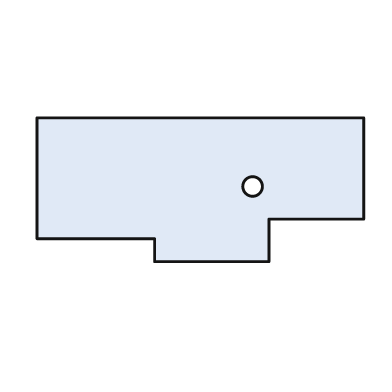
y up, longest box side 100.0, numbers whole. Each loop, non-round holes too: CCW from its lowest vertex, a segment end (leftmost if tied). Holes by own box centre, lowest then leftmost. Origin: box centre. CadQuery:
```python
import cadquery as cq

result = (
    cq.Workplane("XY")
    .moveTo(-14.0, -22.0)
    .lineTo(21.0, -22.0)
    .lineTo(21.0, -9.0)
    .lineTo(50.0, -9.0)
    .lineTo(50.0, 22.0)
    .lineTo(-50.0, 22.0)
    .lineTo(-50.0, -15.0)
    .lineTo(-14.0, -15.0)
    .close()
    .moveTo(16.0, 1.0)
    .circle(3.0)
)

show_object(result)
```